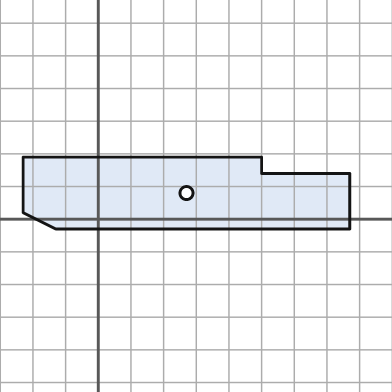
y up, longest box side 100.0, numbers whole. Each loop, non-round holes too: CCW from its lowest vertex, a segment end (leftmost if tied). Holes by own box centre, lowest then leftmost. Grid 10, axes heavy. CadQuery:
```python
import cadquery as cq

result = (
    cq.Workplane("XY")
    .moveTo(-13.0, -3.0)
    .lineTo(77.0, -3.0)
    .lineTo(77.0, 14.0)
    .lineTo(50.0, 14.0)
    .lineTo(50.0, 19.0)
    .lineTo(-23.0, 19.0)
    .lineTo(-23.0, 2.0)
    .close()
    .moveTo(27.0, 8.0)
    .circle(2.0)
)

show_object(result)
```